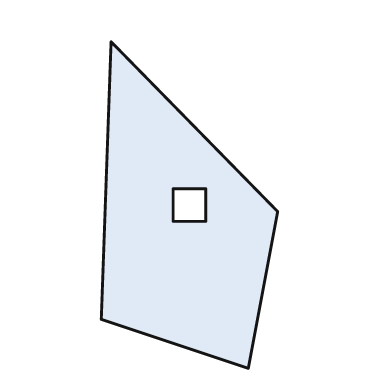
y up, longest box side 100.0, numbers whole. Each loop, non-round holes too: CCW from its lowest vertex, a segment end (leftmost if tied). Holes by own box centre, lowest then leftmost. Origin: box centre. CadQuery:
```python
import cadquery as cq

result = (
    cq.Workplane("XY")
    .moveTo(18.0, -50.0)
    .lineTo(27.0, -2.0)
    .lineTo(-24.0, 50.0)
    .lineTo(-27.0, -35.0)
    .close()
    .moveTo(-5.0, -5.0)
    .lineTo(5.0, -5.0)
    .lineTo(5.0, 5.0)
    .lineTo(-5.0, 5.0)
    .close()
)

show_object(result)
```